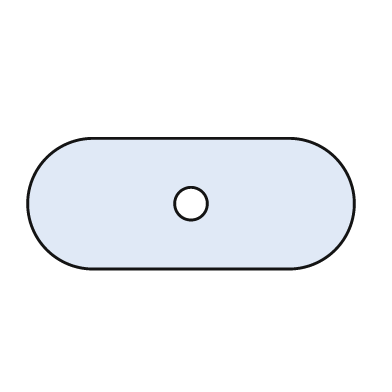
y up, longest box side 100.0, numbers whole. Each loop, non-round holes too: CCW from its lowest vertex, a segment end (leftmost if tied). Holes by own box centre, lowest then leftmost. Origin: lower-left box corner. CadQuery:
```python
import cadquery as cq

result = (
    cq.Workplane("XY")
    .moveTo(20.0, 0.0)
    .lineTo(80.0, 0.0)
    .threePointArc((100.0, 20.0), (80.0, 40.0))
    .lineTo(20.0, 40.0)
    .threePointArc((0.0, 20.0), (20.0, 0.0))
    .close()
    .moveTo(50.0, 20.0)
    .circle(5.0)
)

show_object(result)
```